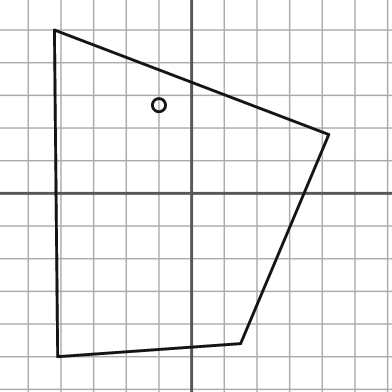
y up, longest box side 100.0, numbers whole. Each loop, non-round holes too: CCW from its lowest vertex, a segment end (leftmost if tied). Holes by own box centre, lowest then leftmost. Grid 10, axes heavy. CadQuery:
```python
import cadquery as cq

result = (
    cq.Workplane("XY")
    .moveTo(-41.0, -50.0)
    .lineTo(15.0, -46.0)
    .lineTo(42.0, 18.0)
    .lineTo(-42.0, 50.0)
    .close()
    .moveTo(-10.0, 27.0)
    .circle(2.0)
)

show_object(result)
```